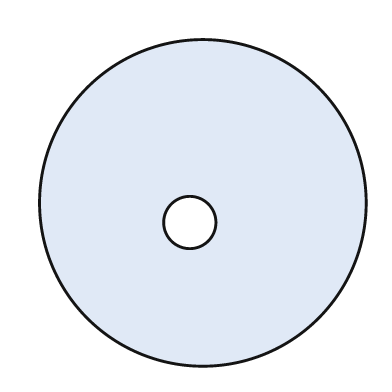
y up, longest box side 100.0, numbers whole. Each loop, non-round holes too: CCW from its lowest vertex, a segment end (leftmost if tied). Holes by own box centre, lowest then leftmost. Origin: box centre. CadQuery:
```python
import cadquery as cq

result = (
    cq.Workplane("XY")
    .moveTo(0.0, 0.0)
    .circle(50.0)
    .moveTo(-4.0, -6.0)
    .circle(8.0)
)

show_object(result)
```